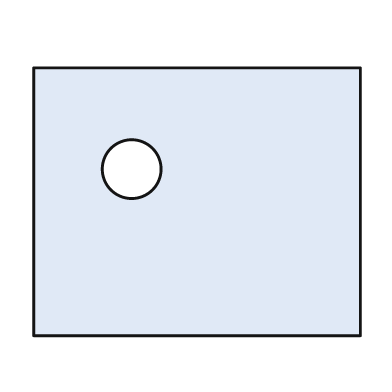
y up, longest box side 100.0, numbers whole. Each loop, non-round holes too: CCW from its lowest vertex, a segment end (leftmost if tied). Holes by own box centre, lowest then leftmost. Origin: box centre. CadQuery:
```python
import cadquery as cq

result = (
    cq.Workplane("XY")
    .moveTo(-50.0, -41.0)
    .lineTo(50.0, -41.0)
    .lineTo(50.0, 41.0)
    .lineTo(-50.0, 41.0)
    .close()
    .moveTo(-20.0, 10.0)
    .circle(9.0)
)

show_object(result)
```